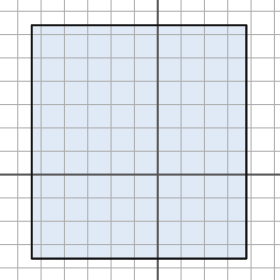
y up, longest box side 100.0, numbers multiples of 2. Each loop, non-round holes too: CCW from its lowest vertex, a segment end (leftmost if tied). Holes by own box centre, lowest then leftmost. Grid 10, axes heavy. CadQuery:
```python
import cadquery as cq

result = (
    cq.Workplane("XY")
    .moveTo(-54.0, -36.0)
    .lineTo(38.0, -36.0)
    .lineTo(38.0, 64.0)
    .lineTo(-54.0, 64.0)
    .close()
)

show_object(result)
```